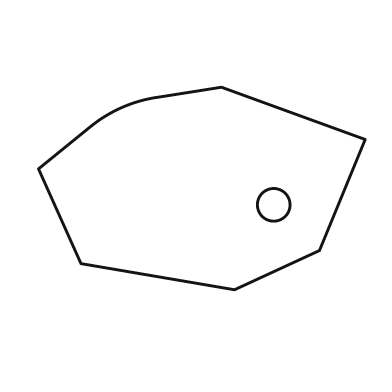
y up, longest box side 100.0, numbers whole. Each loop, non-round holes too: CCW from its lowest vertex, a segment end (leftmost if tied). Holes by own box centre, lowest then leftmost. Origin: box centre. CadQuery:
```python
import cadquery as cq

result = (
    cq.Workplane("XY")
    .moveTo(10.0, -31.0)
    .lineTo(36.0, -19.0)
    .lineTo(50.0, 15.0)
    .lineTo(6.0, 31.0)
    .lineTo(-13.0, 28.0)
    .threePointArc((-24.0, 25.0), (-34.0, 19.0))
    .lineTo(-50.0, 6.0)
    .lineTo(-37.0, -23.0)
    .close()
    .moveTo(22.0, -5.0)
    .circle(5.0)
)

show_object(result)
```